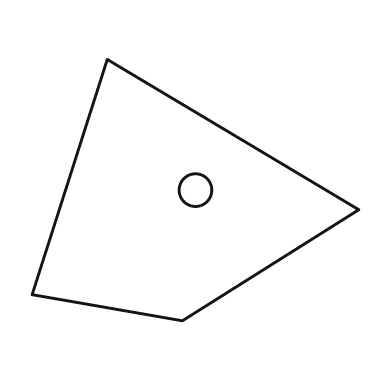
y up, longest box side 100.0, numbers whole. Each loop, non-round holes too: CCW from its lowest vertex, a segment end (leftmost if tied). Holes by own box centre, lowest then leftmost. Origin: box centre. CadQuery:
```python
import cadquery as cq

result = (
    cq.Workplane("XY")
    .moveTo(-4.0, -40.0)
    .lineTo(50.0, -6.0)
    .lineTo(-27.0, 40.0)
    .lineTo(-50.0, -32.0)
    .close()
    .moveTo(0.0, 0.0)
    .circle(5.0)
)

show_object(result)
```